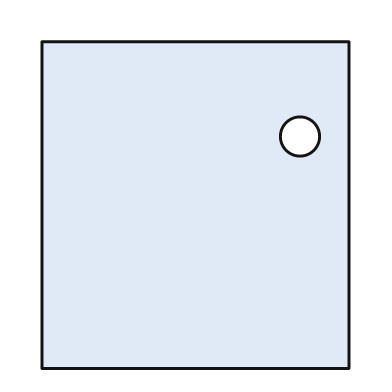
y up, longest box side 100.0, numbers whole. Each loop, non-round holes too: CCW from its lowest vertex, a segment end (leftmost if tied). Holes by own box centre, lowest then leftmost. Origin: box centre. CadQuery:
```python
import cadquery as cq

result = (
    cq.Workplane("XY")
    .moveTo(-47.0, -50.0)
    .lineTo(47.0, -50.0)
    .lineTo(47.0, 50.0)
    .lineTo(-47.0, 50.0)
    .close()
    .moveTo(32.0, 21.0)
    .circle(6.0)
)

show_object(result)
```